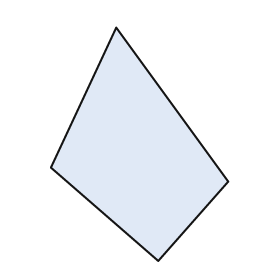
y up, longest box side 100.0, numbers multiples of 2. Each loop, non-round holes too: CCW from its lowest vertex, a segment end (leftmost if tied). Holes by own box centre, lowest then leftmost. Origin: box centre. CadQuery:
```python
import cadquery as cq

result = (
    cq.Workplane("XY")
    .moveTo(8.0, -50.0)
    .lineTo(38.0, -16.0)
    .lineTo(-10.0, 50.0)
    .lineTo(-38.0, -10.0)
    .close()
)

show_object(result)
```